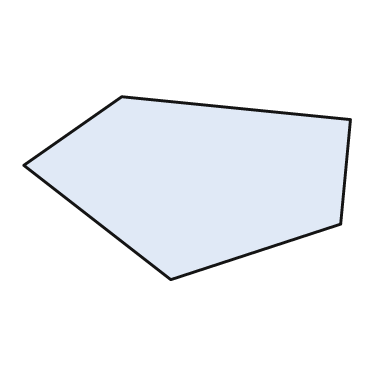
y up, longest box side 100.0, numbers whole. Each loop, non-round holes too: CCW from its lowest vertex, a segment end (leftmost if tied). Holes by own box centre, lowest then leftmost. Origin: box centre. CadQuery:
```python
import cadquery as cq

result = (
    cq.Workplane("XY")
    .moveTo(-5.0, -28.0)
    .lineTo(47.0, -11.0)
    .lineTo(50.0, 21.0)
    .lineTo(-20.0, 28.0)
    .lineTo(-50.0, 7.0)
    .close()
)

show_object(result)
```